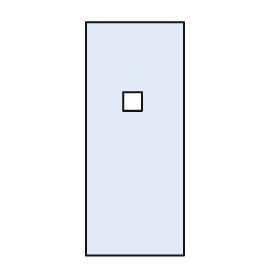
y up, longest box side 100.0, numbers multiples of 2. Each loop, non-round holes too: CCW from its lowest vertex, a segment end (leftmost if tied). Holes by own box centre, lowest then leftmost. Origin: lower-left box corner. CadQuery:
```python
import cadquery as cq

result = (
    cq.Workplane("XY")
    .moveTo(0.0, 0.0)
    .lineTo(42.0, 0.0)
    .lineTo(42.0, 100.0)
    .lineTo(0.0, 100.0)
    .close()
    .moveTo(16.0, 62.0)
    .lineTo(24.0, 62.0)
    .lineTo(24.0, 70.0)
    .lineTo(16.0, 70.0)
    .close()
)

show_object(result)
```